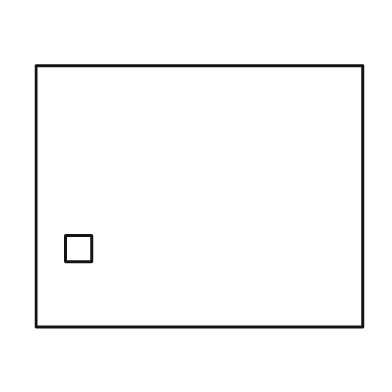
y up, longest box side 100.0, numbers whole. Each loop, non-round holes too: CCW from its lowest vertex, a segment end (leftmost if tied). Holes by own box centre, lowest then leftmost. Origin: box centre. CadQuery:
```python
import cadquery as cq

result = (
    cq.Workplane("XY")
    .moveTo(-50.0, -40.0)
    .lineTo(50.0, -40.0)
    .lineTo(50.0, 40.0)
    .lineTo(-50.0, 40.0)
    .close()
    .moveTo(-41.0, -20.0)
    .lineTo(-33.0, -20.0)
    .lineTo(-33.0, -12.0)
    .lineTo(-41.0, -12.0)
    .close()
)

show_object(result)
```